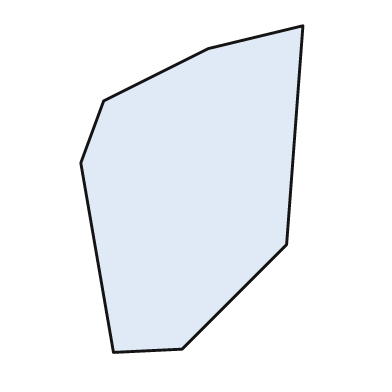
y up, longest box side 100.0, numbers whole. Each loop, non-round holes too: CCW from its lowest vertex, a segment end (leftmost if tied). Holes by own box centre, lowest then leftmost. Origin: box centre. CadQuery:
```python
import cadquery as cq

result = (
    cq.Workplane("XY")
    .moveTo(-24.0, -50.0)
    .lineTo(-3.0, -49.0)
    .lineTo(29.0, -17.0)
    .lineTo(34.0, 50.0)
    .lineTo(5.0, 43.0)
    .lineTo(-27.0, 27.0)
    .lineTo(-34.0, 8.0)
    .close()
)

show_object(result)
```